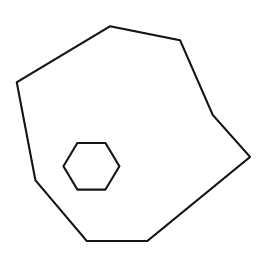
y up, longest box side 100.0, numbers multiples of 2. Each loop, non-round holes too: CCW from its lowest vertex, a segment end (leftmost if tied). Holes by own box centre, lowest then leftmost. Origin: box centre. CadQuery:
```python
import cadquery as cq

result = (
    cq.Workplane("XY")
    .moveTo(-20.0, -46.0)
    .lineTo(6.0, -46.0)
    .lineTo(50.0, -10.0)
    .lineTo(34.0, 8.0)
    .lineTo(20.0, 40.0)
    .lineTo(-10.0, 46.0)
    .lineTo(-50.0, 22.0)
    .lineTo(-42.0, -20.0)
    .close()
    .moveTo(-24.0, -24.0)
    .lineTo(-12.0, -24.0)
    .lineTo(-6.0, -14.0)
    .lineTo(-12.0, -4.0)
    .lineTo(-24.0, -4.0)
    .lineTo(-30.0, -14.0)
    .close()
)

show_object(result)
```